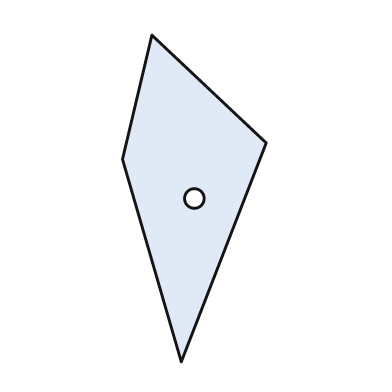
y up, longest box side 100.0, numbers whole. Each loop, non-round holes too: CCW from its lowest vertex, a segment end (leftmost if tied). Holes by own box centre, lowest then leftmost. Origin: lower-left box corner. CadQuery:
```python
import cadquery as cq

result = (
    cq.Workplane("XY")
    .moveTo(18.0, 0.0)
    .lineTo(44.0, 67.0)
    .lineTo(9.0, 100.0)
    .lineTo(0.0, 62.0)
    .close()
    .moveTo(22.0, 50.0)
    .circle(3.0)
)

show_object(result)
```